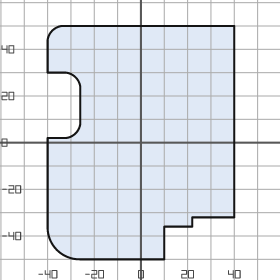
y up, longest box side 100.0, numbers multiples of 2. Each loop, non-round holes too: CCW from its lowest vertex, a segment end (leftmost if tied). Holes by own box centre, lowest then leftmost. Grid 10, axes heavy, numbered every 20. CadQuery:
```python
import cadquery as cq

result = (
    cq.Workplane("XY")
    .moveTo(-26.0, -50.0)
    .lineTo(10.0, -50.0)
    .lineTo(10.0, -36.0)
    .lineTo(22.0, -36.0)
    .lineTo(22.0, -32.0)
    .lineTo(40.0, -32.0)
    .lineTo(40.0, 50.0)
    .lineTo(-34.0, 50.0)
    .threePointArc((-38.0, 48.0), (-40.0, 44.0))
    .lineTo(-40.0, 30.0)
    .lineTo(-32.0, 30.0)
    .threePointArc((-28.0, 28.0), (-26.0, 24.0))
    .lineTo(-26.0, 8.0)
    .threePointArc((-28.0, 4.0), (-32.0, 2.0))
    .lineTo(-40.0, 2.0)
    .lineTo(-40.0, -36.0)
    .threePointArc((-36.0, -46.0), (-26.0, -50.0))
    .close()
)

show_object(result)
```